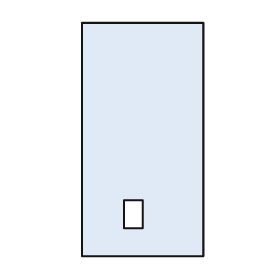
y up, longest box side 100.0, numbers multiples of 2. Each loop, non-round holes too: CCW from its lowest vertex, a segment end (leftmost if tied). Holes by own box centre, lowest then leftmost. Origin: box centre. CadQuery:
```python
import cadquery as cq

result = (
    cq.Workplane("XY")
    .moveTo(-26.0, -50.0)
    .lineTo(26.0, -50.0)
    .lineTo(26.0, 50.0)
    .lineTo(-26.0, 50.0)
    .close()
    .moveTo(-8.0, -38.0)
    .lineTo(0.0, -38.0)
    .lineTo(0.0, -26.0)
    .lineTo(-8.0, -26.0)
    .close()
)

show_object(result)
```